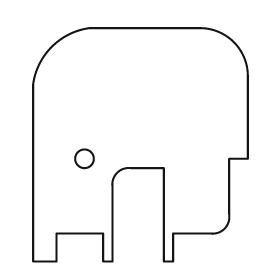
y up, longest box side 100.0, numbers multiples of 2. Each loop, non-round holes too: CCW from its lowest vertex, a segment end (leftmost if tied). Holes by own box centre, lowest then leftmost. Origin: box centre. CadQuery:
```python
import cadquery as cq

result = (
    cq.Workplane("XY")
    .moveTo(-46.0, -50.0)
    .lineTo(-36.0, -50.0)
    .lineTo(-36.0, -38.0)
    .lineTo(-16.0, -38.0)
    .lineTo(-16.0, -50.0)
    .lineTo(-12.0, -50.0)
    .lineTo(-12.0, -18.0)
    .threePointArc((-10.0, -12.0), (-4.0, -10.0))
    .lineTo(10.0, -10.0)
    .lineTo(10.0, -50.0)
    .lineTo(14.0, -50.0)
    .lineTo(14.0, -38.0)
    .lineTo(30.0, -38.0)
    .threePointArc((36.0, -36.0), (38.0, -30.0))
    .lineTo(38.0, -6.0)
    .lineTo(46.0, -6.0)
    .lineTo(46.0, 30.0)
    .threePointArc((40.0, 44.0), (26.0, 50.0))
    .lineTo(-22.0, 50.0)
    .threePointArc((-38.0, 42.0), (-46.0, 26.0))
    .close()
    .moveTo(-24.0, -6.0)
    .circle(4.0)
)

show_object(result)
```